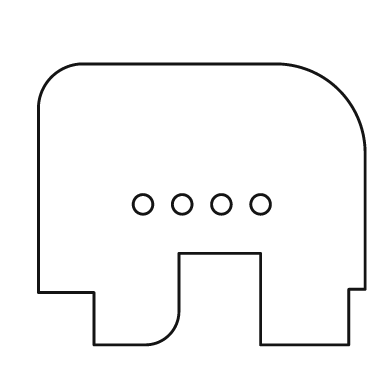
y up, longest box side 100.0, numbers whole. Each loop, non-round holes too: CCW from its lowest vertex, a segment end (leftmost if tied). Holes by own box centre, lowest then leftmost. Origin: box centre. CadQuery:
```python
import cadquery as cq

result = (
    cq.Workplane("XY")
    .moveTo(-33.0, -43.0)
    .lineTo(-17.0, -43.0)
    .threePointArc((-10.0, -40.0), (-7.0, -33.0))
    .lineTo(-7.0, -15.0)
    .lineTo(18.0, -15.0)
    .lineTo(18.0, -43.0)
    .lineTo(45.0, -43.0)
    .lineTo(45.0, -26.0)
    .lineTo(50.0, -26.0)
    .lineTo(50.0, 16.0)
    .threePointArc((42.0, 35.0), (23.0, 43.0))
    .lineTo(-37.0, 43.0)
    .threePointArc((-46.0, 39.0), (-50.0, 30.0))
    .lineTo(-50.0, -27.0)
    .lineTo(-33.0, -27.0)
    .close()
    .moveTo(-18.0, 0.0)
    .circle(3.0)
    .moveTo(-6.0, 0.0)
    .circle(3.0)
    .moveTo(6.0, 0.0)
    .circle(3.0)
    .moveTo(18.0, 0.0)
    .circle(3.0)
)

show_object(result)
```